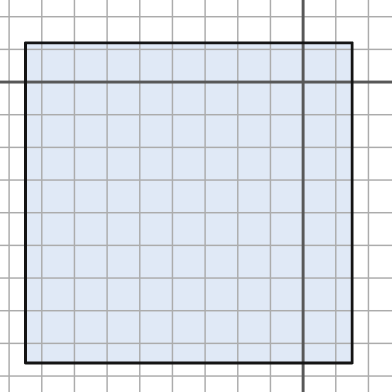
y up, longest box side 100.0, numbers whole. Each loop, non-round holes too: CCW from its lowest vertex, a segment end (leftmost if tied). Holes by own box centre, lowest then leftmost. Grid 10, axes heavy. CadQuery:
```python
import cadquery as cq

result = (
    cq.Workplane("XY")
    .moveTo(-85.0, -86.0)
    .lineTo(15.0, -86.0)
    .lineTo(15.0, 12.0)
    .lineTo(-85.0, 12.0)
    .close()
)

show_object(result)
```